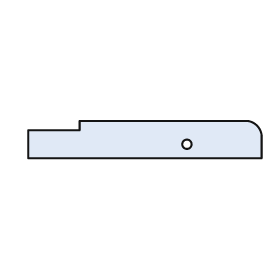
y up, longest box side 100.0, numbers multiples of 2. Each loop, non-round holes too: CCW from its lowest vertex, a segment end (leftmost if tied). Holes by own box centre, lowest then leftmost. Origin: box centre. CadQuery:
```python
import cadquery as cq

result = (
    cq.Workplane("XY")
    .moveTo(-50.0, -8.0)
    .lineTo(50.0, -8.0)
    .lineTo(50.0, 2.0)
    .threePointArc((48.0, 6.0), (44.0, 8.0))
    .lineTo(-28.0, 8.0)
    .lineTo(-28.0, 4.0)
    .lineTo(-50.0, 4.0)
    .close()
    .moveTo(18.0, -2.0)
    .circle(2.0)
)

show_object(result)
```